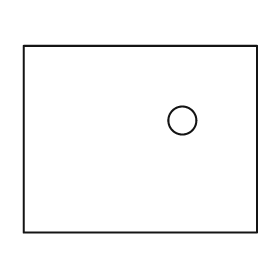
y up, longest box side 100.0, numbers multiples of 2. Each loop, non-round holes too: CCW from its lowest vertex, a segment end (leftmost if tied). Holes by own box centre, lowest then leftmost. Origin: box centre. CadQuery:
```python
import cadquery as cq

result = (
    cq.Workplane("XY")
    .moveTo(-50.0, -40.0)
    .lineTo(50.0, -40.0)
    .lineTo(50.0, 40.0)
    .lineTo(-50.0, 40.0)
    .close()
    .moveTo(18.0, 8.0)
    .circle(6.0)
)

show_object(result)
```